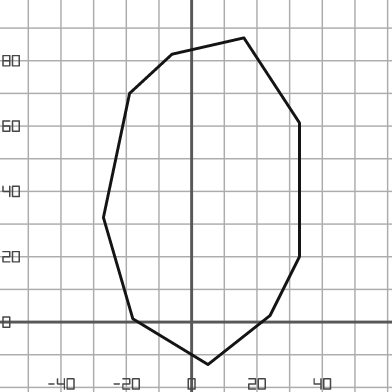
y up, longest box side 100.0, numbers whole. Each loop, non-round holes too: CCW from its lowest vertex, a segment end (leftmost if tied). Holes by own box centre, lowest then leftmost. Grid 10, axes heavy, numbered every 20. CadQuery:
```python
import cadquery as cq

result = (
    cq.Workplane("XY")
    .moveTo(5.0, -13.0)
    .lineTo(24.0, 2.0)
    .lineTo(33.0, 20.0)
    .lineTo(33.0, 61.0)
    .lineTo(16.0, 87.0)
    .lineTo(-6.0, 82.0)
    .lineTo(-19.0, 70.0)
    .lineTo(-27.0, 32.0)
    .lineTo(-18.0, 1.0)
    .close()
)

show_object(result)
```